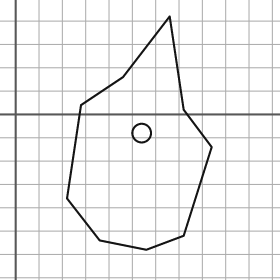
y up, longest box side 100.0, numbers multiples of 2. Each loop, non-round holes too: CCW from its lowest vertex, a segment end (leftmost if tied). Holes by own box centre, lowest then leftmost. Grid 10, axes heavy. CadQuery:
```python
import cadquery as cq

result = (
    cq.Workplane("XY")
    .moveTo(56.0, -58.0)
    .lineTo(72.0, -52.0)
    .lineTo(84.0, -14.0)
    .lineTo(72.0, 2.0)
    .lineTo(66.0, 42.0)
    .lineTo(46.0, 16.0)
    .lineTo(28.0, 4.0)
    .lineTo(22.0, -36.0)
    .lineTo(36.0, -54.0)
    .close()
    .moveTo(54.0, -8.0)
    .circle(4.0)
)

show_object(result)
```